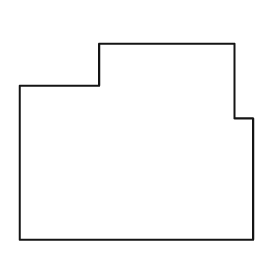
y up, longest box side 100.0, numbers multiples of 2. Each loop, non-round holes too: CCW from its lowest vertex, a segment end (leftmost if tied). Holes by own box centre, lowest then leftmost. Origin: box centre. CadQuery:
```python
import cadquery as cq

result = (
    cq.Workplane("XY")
    .moveTo(-50.0, -42.0)
    .lineTo(50.0, -42.0)
    .lineTo(50.0, 10.0)
    .lineTo(42.0, 10.0)
    .lineTo(42.0, 42.0)
    .lineTo(-16.0, 42.0)
    .lineTo(-16.0, 24.0)
    .lineTo(-50.0, 24.0)
    .close()
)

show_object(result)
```